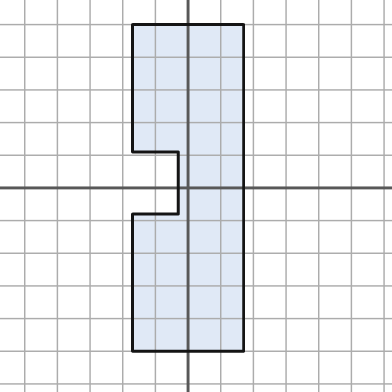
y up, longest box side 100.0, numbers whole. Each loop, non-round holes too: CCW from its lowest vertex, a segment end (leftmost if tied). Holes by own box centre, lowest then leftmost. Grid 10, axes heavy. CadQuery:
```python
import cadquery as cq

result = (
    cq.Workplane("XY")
    .moveTo(-17.0, -50.0)
    .lineTo(17.0, -50.0)
    .lineTo(17.0, 50.0)
    .lineTo(-17.0, 50.0)
    .lineTo(-17.0, 11.0)
    .lineTo(-3.0, 11.0)
    .lineTo(-3.0, -8.0)
    .lineTo(-17.0, -8.0)
    .close()
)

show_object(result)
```